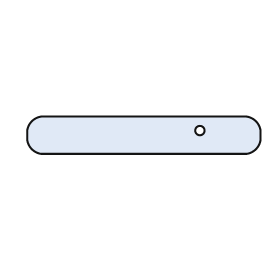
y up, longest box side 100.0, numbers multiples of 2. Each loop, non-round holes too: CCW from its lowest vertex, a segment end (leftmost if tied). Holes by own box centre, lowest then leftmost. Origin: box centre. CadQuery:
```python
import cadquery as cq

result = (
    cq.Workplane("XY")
    .moveTo(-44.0, -8.0)
    .lineTo(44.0, -8.0)
    .threePointArc((48.0, -6.0), (50.0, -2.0))
    .lineTo(50.0, 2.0)
    .threePointArc((48.0, 6.0), (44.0, 8.0))
    .lineTo(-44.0, 8.0)
    .threePointArc((-48.0, 6.0), (-50.0, 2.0))
    .lineTo(-50.0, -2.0)
    .threePointArc((-48.0, -6.0), (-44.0, -8.0))
    .close()
    .moveTo(24.0, 2.0)
    .circle(2.0)
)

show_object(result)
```